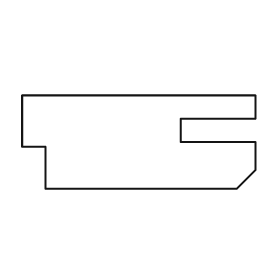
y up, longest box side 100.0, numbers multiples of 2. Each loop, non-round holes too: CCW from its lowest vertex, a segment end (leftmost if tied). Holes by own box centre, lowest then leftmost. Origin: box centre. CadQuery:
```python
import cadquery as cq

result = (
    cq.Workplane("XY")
    .moveTo(-40.0, -20.0)
    .lineTo(42.0, -20.0)
    .lineTo(50.0, -12.0)
    .lineTo(50.0, 0.0)
    .lineTo(18.0, 0.0)
    .lineTo(18.0, 10.0)
    .lineTo(50.0, 10.0)
    .lineTo(50.0, 20.0)
    .lineTo(-50.0, 20.0)
    .lineTo(-50.0, -2.0)
    .lineTo(-40.0, -2.0)
    .close()
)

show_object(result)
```